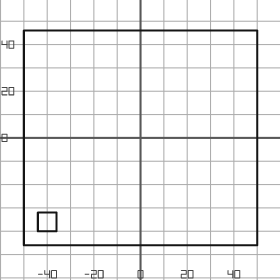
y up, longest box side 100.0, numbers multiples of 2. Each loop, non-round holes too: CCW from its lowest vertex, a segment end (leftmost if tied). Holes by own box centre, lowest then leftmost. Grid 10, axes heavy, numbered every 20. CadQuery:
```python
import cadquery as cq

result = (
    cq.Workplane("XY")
    .moveTo(-50.0, -46.0)
    .lineTo(50.0, -46.0)
    .lineTo(50.0, 46.0)
    .lineTo(-50.0, 46.0)
    .close()
    .moveTo(-44.0, -40.0)
    .lineTo(-36.0, -40.0)
    .lineTo(-36.0, -32.0)
    .lineTo(-44.0, -32.0)
    .close()
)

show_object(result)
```